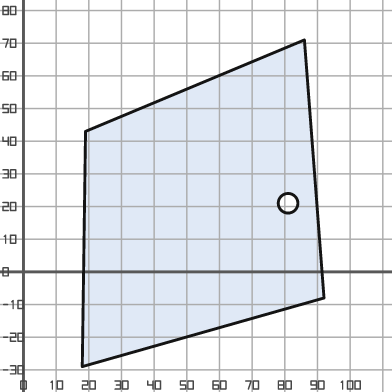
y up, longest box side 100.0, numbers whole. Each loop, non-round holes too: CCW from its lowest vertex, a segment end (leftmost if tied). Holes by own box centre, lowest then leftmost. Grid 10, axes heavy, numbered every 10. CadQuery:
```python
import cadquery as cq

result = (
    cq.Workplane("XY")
    .moveTo(18.0, -29.0)
    .lineTo(92.0, -8.0)
    .lineTo(86.0, 71.0)
    .lineTo(19.0, 43.0)
    .close()
    .moveTo(81.0, 21.0)
    .circle(3.0)
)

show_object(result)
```